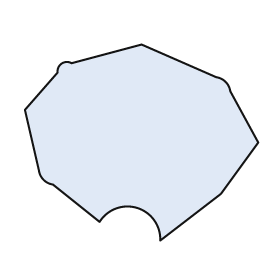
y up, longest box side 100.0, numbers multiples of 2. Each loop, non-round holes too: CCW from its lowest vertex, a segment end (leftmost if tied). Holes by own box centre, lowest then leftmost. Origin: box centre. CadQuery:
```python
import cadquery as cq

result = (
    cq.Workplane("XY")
    .moveTo(8.0, -42.0)
    .lineTo(34.0, -22.0)
    .lineTo(50.0, 0.0)
    .lineTo(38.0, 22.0)
    .threePointArc((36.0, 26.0), (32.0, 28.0))
    .lineTo(0.0, 42.0)
    .lineTo(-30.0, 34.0)
    .threePointArc((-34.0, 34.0), (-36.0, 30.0))
    .lineTo(-50.0, 14.0)
    .lineTo(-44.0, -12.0)
    .threePointArc((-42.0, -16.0), (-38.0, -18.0))
    .lineTo(-18.0, -34.0)
    .threePointArc((-2.0, -28.0), (8.0, -42.0))
    .close()
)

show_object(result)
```